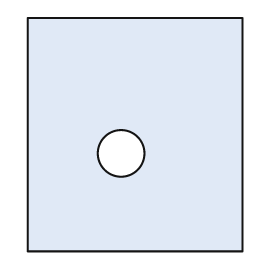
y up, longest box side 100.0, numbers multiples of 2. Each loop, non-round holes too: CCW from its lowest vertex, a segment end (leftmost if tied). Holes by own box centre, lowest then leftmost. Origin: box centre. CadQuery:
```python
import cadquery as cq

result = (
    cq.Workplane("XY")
    .moveTo(-46.0, -50.0)
    .lineTo(46.0, -50.0)
    .lineTo(46.0, 50.0)
    .lineTo(-46.0, 50.0)
    .close()
    .moveTo(-6.0, -8.0)
    .circle(10.0)
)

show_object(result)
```